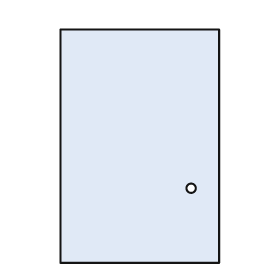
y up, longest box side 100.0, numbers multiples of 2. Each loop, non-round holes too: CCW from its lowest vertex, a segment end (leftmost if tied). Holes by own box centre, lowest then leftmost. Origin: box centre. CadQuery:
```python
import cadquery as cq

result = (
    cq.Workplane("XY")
    .moveTo(-34.0, -50.0)
    .lineTo(34.0, -50.0)
    .lineTo(34.0, 50.0)
    .lineTo(-34.0, 50.0)
    .close()
    .moveTo(22.0, -18.0)
    .circle(2.0)
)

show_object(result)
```